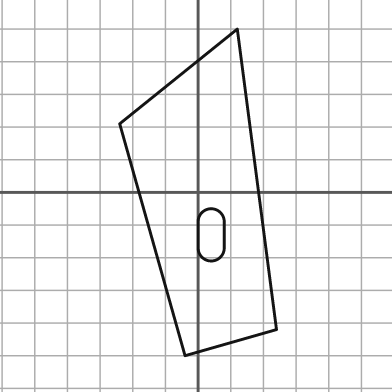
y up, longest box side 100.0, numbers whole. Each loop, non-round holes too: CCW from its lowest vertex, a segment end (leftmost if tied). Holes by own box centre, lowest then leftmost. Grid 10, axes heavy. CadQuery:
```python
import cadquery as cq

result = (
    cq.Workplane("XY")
    .moveTo(-4.0, -50.0)
    .lineTo(24.0, -42.0)
    .lineTo(12.0, 50.0)
    .lineTo(-24.0, 21.0)
    .close()
    .moveTo(0.0, -17.0)
    .threePointArc((4.0, -21.0), (8.0, -17.0))
    .lineTo(8.0, -9.0)
    .threePointArc((4.0, -5.0), (0.0, -9.0))
    .close()
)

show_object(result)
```